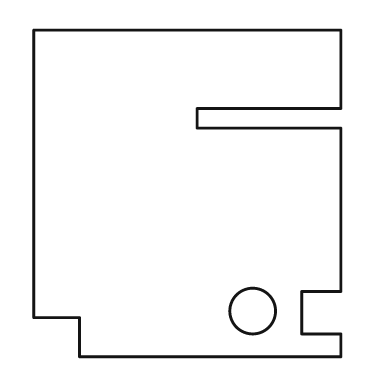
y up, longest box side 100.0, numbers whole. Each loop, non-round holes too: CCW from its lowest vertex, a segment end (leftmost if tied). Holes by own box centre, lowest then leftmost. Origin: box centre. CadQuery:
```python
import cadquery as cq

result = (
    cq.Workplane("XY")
    .moveTo(-33.0, -50.0)
    .lineTo(47.0, -50.0)
    .lineTo(47.0, -43.0)
    .lineTo(35.0, -43.0)
    .lineTo(35.0, -30.0)
    .lineTo(47.0, -30.0)
    .lineTo(47.0, 20.0)
    .lineTo(3.0, 20.0)
    .lineTo(3.0, 26.0)
    .lineTo(47.0, 26.0)
    .lineTo(47.0, 50.0)
    .lineTo(-47.0, 50.0)
    .lineTo(-47.0, -38.0)
    .lineTo(-33.0, -38.0)
    .close()
    .moveTo(20.0, -36.0)
    .circle(7.0)
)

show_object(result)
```